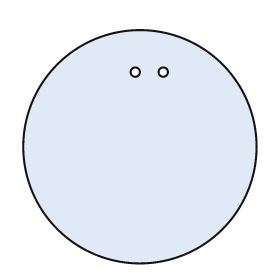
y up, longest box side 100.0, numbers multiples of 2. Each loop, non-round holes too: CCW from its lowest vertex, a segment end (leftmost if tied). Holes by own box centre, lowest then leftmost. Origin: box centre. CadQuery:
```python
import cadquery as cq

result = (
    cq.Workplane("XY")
    .moveTo(0.0, 0.0)
    .circle(50.0)
    .moveTo(-2.0, 32.0)
    .circle(2.0)
    .moveTo(10.0, 32.0)
    .circle(2.0)
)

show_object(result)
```